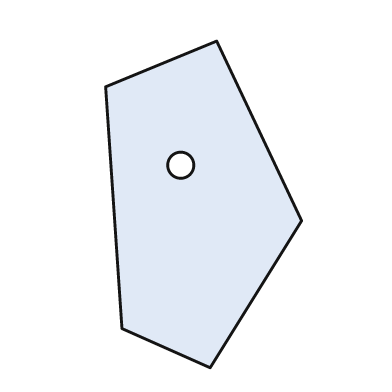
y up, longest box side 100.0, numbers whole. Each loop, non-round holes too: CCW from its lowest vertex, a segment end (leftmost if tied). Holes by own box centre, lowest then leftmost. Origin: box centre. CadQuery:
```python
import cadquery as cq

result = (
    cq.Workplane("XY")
    .moveTo(2.0, -50.0)
    .lineTo(30.0, -5.0)
    .lineTo(4.0, 50.0)
    .lineTo(-30.0, 36.0)
    .lineTo(-25.0, -38.0)
    .close()
    .moveTo(-7.0, 12.0)
    .circle(4.0)
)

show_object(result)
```